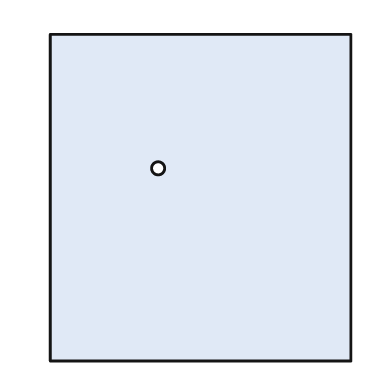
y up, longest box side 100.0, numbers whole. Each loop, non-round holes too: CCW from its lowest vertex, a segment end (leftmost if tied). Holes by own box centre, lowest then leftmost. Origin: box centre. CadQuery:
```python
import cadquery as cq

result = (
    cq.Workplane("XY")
    .moveTo(-46.0, -50.0)
    .lineTo(46.0, -50.0)
    .lineTo(46.0, 50.0)
    .lineTo(-46.0, 50.0)
    .close()
    .moveTo(-13.0, 9.0)
    .circle(2.0)
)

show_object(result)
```